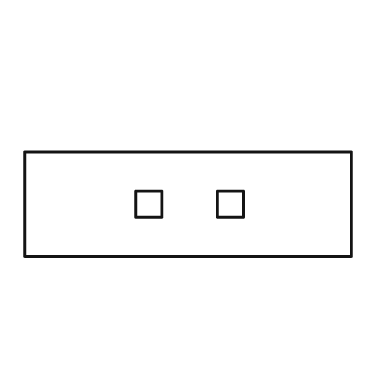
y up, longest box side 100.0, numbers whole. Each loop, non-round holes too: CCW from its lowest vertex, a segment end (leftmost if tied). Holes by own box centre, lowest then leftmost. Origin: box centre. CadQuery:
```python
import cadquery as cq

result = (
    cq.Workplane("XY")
    .moveTo(-50.0, -16.0)
    .lineTo(50.0, -16.0)
    .lineTo(50.0, 16.0)
    .lineTo(-50.0, 16.0)
    .close()
    .moveTo(-16.0, -4.0)
    .lineTo(-8.0, -4.0)
    .lineTo(-8.0, 4.0)
    .lineTo(-16.0, 4.0)
    .close()
    .moveTo(9.0, -4.0)
    .lineTo(17.0, -4.0)
    .lineTo(17.0, 4.0)
    .lineTo(9.0, 4.0)
    .close()
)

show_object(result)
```